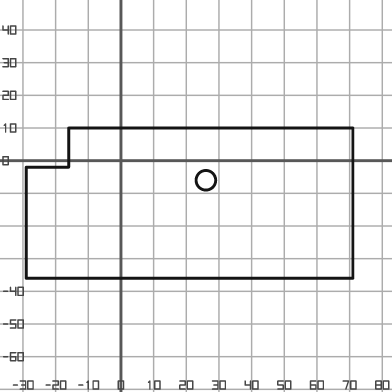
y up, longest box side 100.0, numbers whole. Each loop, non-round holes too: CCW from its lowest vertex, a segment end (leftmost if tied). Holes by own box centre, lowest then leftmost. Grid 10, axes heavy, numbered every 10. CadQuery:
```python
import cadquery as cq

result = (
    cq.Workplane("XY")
    .moveTo(-29.0, -36.0)
    .lineTo(71.0, -36.0)
    .lineTo(71.0, 10.0)
    .lineTo(-16.0, 10.0)
    .lineTo(-16.0, -2.0)
    .lineTo(-29.0, -2.0)
    .close()
    .moveTo(26.0, -6.0)
    .circle(3.0)
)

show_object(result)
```